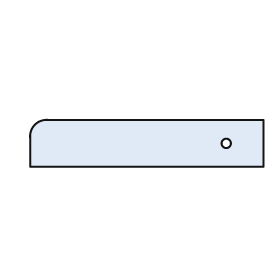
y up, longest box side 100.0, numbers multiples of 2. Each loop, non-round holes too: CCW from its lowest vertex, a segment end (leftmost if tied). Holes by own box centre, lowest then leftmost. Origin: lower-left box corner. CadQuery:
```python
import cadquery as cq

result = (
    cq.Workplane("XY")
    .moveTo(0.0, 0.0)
    .lineTo(100.0, 0.0)
    .lineTo(100.0, 20.0)
    .lineTo(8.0, 20.0)
    .threePointArc((2.0, 18.0), (0.0, 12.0))
    .close()
    .moveTo(84.0, 10.0)
    .circle(2.0)
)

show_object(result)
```